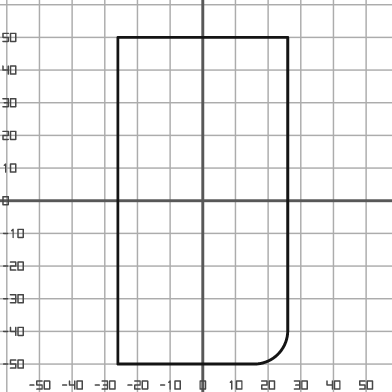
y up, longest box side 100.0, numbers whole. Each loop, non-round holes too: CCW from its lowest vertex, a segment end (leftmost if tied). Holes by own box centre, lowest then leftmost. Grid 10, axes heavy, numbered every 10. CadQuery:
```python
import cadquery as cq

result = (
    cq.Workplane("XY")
    .moveTo(-26.0, -50.0)
    .lineTo(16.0, -50.0)
    .threePointArc((23.0, -47.0), (26.0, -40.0))
    .lineTo(26.0, 50.0)
    .lineTo(-26.0, 50.0)
    .close()
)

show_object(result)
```